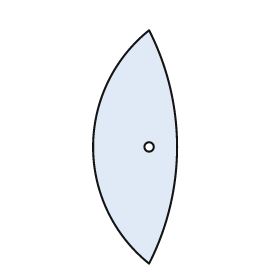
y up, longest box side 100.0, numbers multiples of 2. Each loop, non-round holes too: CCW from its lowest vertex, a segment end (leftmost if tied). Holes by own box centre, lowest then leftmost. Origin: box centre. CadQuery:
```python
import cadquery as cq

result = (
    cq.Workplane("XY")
    .moveTo(6.0, -50.0)
    .threePointArc((18.0, 0.0), (6.0, 50.0))
    .threePointArc((-18.0, 0.0), (6.0, -50.0))
    .close()
    .moveTo(6.0, 0.0)
    .circle(2.0)
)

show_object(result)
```